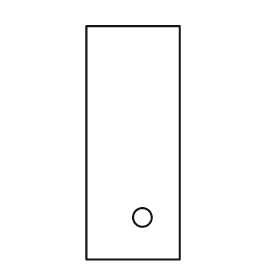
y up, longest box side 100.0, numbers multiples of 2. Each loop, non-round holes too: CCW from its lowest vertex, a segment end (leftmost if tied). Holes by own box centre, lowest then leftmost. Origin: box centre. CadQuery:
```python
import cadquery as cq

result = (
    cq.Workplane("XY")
    .moveTo(-20.0, -50.0)
    .lineTo(20.0, -50.0)
    .lineTo(20.0, 50.0)
    .lineTo(-20.0, 50.0)
    .close()
    .moveTo(4.0, -32.0)
    .circle(4.0)
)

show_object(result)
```